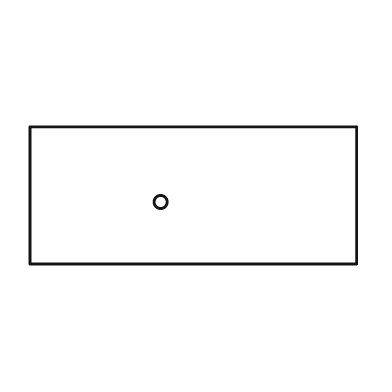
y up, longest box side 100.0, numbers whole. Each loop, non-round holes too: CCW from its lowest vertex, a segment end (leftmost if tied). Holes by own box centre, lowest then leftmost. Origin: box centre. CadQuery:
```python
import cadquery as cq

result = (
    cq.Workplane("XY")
    .moveTo(-50.0, -21.0)
    .lineTo(50.0, -21.0)
    .lineTo(50.0, 21.0)
    .lineTo(-50.0, 21.0)
    .close()
    .moveTo(-10.0, -2.0)
    .circle(2.0)
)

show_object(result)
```